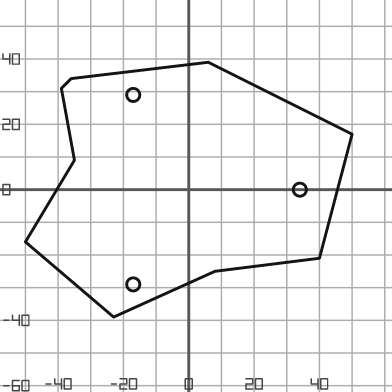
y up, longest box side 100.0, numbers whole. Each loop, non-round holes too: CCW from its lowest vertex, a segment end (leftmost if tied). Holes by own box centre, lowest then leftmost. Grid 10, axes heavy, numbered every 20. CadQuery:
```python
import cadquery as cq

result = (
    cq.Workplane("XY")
    .moveTo(-23.0, -39.0)
    .lineTo(8.0, -25.0)
    .lineTo(40.0, -21.0)
    .lineTo(50.0, 17.0)
    .lineTo(6.0, 39.0)
    .lineTo(-36.0, 34.0)
    .lineTo(-39.0, 31.0)
    .lineTo(-35.0, 9.0)
    .lineTo(-50.0, -16.0)
    .close()
    .moveTo(-17.0, -29.0)
    .circle(2.0)
    .moveTo(34.0, 0.0)
    .circle(2.0)
    .moveTo(-17.0, 29.0)
    .circle(2.0)
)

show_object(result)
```